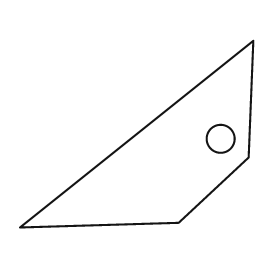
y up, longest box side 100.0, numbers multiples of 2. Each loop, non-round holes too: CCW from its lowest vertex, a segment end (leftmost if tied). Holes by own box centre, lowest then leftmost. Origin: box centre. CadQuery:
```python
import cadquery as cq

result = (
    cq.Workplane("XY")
    .moveTo(-50.0, -40.0)
    .lineTo(18.0, -38.0)
    .lineTo(48.0, -10.0)
    .lineTo(50.0, 40.0)
    .close()
    .moveTo(36.0, -2.0)
    .circle(6.0)
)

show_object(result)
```